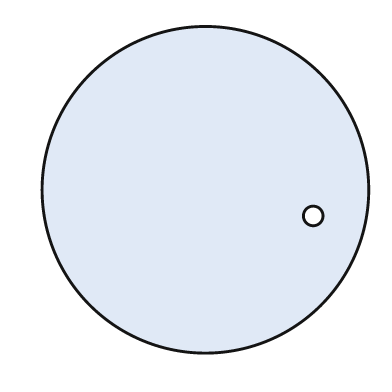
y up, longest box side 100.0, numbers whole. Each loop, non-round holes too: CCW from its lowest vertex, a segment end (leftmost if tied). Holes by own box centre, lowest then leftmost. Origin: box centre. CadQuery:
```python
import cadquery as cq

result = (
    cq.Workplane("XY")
    .moveTo(0.0, 0.0)
    .circle(50.0)
    .moveTo(33.0, -8.0)
    .circle(3.0)
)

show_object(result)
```